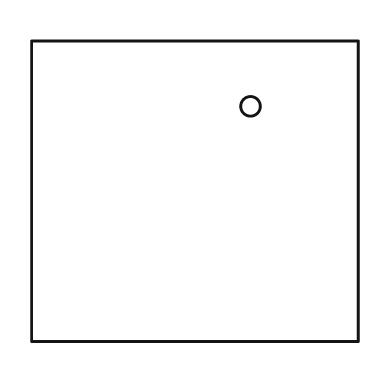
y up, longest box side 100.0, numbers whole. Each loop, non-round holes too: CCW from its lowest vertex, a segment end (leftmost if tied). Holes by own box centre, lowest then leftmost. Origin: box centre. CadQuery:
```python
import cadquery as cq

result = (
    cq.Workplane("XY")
    .moveTo(-50.0, -46.0)
    .lineTo(50.0, -46.0)
    .lineTo(50.0, 46.0)
    .lineTo(-50.0, 46.0)
    .close()
    .moveTo(17.0, 26.0)
    .circle(3.0)
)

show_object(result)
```